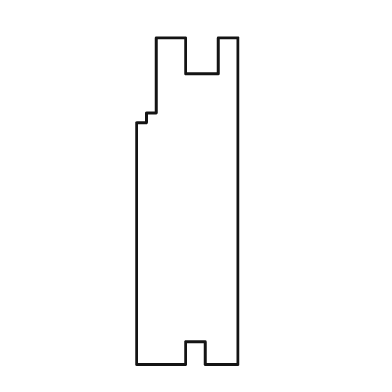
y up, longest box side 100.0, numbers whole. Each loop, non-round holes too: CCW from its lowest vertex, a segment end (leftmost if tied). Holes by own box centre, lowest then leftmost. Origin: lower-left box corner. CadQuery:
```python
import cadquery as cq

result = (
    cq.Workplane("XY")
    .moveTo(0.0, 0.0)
    .lineTo(15.0, 0.0)
    .lineTo(15.0, 7.0)
    .lineTo(21.0, 7.0)
    .lineTo(21.0, 0.0)
    .lineTo(31.0, 0.0)
    .lineTo(31.0, 100.0)
    .lineTo(25.0, 100.0)
    .lineTo(25.0, 89.0)
    .lineTo(15.0, 89.0)
    .lineTo(15.0, 100.0)
    .lineTo(6.0, 100.0)
    .lineTo(6.0, 77.0)
    .lineTo(3.0, 77.0)
    .lineTo(3.0, 74.0)
    .lineTo(0.0, 74.0)
    .close()
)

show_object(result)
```